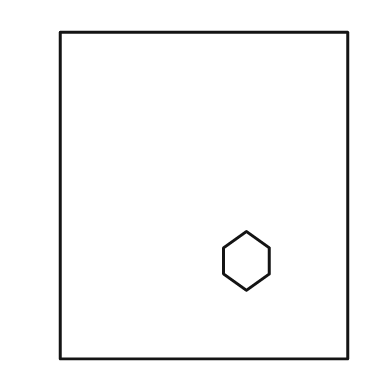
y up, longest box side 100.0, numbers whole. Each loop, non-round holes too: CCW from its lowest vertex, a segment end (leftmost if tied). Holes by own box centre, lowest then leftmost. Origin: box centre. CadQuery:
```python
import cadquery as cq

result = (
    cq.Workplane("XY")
    .moveTo(-44.0, -50.0)
    .lineTo(44.0, -50.0)
    .lineTo(44.0, 50.0)
    .lineTo(-44.0, 50.0)
    .close()
    .moveTo(13.0, -29.0)
    .lineTo(20.0, -24.0)
    .lineTo(20.0, -16.0)
    .lineTo(13.0, -11.0)
    .lineTo(6.0, -16.0)
    .lineTo(6.0, -24.0)
    .close()
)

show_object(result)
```